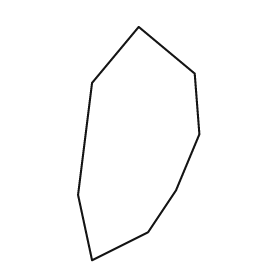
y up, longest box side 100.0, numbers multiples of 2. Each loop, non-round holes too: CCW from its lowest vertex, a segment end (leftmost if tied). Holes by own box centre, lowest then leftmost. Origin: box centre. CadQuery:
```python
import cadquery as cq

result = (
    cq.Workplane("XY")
    .moveTo(-20.0, -50.0)
    .lineTo(4.0, -38.0)
    .lineTo(16.0, -20.0)
    .lineTo(26.0, 4.0)
    .lineTo(24.0, 30.0)
    .lineTo(0.0, 50.0)
    .lineTo(-20.0, 26.0)
    .lineTo(-26.0, -22.0)
    .close()
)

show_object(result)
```